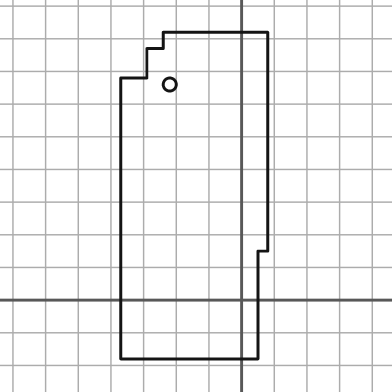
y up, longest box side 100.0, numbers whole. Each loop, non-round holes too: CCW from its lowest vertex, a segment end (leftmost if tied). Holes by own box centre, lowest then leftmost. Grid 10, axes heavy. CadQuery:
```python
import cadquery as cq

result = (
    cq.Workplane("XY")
    .moveTo(-37.0, -18.0)
    .lineTo(5.0, -18.0)
    .lineTo(5.0, 15.0)
    .lineTo(8.0, 15.0)
    .lineTo(8.0, 82.0)
    .lineTo(-24.0, 82.0)
    .lineTo(-24.0, 77.0)
    .lineTo(-29.0, 77.0)
    .lineTo(-29.0, 68.0)
    .lineTo(-37.0, 68.0)
    .close()
    .moveTo(-22.0, 66.0)
    .circle(2.0)
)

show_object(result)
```